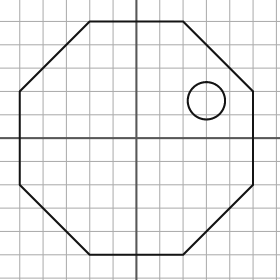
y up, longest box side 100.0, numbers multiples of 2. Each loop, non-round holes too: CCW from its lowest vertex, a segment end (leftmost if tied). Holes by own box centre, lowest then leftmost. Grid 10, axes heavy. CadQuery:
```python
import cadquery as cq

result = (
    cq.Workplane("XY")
    .moveTo(-20.0, -50.0)
    .lineTo(20.0, -50.0)
    .lineTo(50.0, -20.0)
    .lineTo(50.0, 20.0)
    .lineTo(20.0, 50.0)
    .lineTo(-20.0, 50.0)
    .lineTo(-50.0, 20.0)
    .lineTo(-50.0, -20.0)
    .close()
    .moveTo(30.0, 16.0)
    .circle(8.0)
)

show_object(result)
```